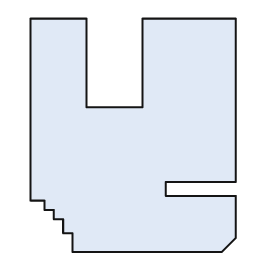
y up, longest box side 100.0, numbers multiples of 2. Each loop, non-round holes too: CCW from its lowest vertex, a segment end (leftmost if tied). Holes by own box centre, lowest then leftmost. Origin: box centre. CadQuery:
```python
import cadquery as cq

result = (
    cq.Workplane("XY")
    .moveTo(-26.0, -50.0)
    .lineTo(38.0, -50.0)
    .lineTo(44.0, -44.0)
    .lineTo(44.0, -26.0)
    .lineTo(14.0, -26.0)
    .lineTo(14.0, -20.0)
    .lineTo(44.0, -20.0)
    .lineTo(44.0, 50.0)
    .lineTo(4.0, 50.0)
    .lineTo(4.0, 12.0)
    .lineTo(-20.0, 12.0)
    .lineTo(-20.0, 50.0)
    .lineTo(-44.0, 50.0)
    .lineTo(-44.0, -28.0)
    .lineTo(-38.0, -28.0)
    .lineTo(-38.0, -32.0)
    .lineTo(-34.0, -32.0)
    .lineTo(-34.0, -36.0)
    .lineTo(-30.0, -36.0)
    .lineTo(-30.0, -42.0)
    .lineTo(-26.0, -42.0)
    .close()
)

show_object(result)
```